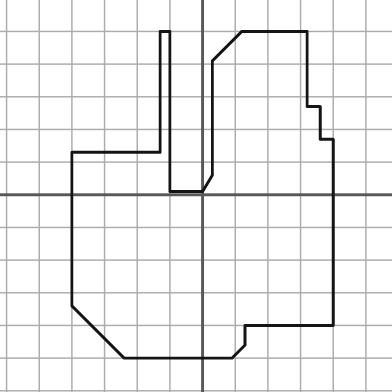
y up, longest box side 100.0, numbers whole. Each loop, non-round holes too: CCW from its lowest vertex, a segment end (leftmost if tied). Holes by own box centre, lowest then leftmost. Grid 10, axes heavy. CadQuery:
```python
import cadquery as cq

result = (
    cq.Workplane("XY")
    .moveTo(-24.0, -50.0)
    .lineTo(9.0, -50.0)
    .lineTo(13.0, -46.0)
    .lineTo(13.0, -40.0)
    .lineTo(40.0, -40.0)
    .lineTo(40.0, 17.0)
    .lineTo(36.0, 17.0)
    .lineTo(36.0, 27.0)
    .lineTo(32.0, 27.0)
    .lineTo(32.0, 50.0)
    .lineTo(12.0, 50.0)
    .lineTo(3.0, 41.0)
    .lineTo(3.0, 6.0)
    .lineTo(0.0, 1.0)
    .lineTo(-10.0, 1.0)
    .lineTo(-10.0, 50.0)
    .lineTo(-13.0, 50.0)
    .lineTo(-13.0, 13.0)
    .lineTo(-40.0, 13.0)
    .lineTo(-40.0, -34.0)
    .close()
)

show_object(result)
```